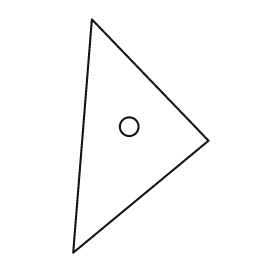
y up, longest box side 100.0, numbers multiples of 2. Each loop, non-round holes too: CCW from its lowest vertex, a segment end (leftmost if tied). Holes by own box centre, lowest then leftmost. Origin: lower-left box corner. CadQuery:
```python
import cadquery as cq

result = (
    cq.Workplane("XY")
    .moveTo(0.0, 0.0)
    .lineTo(58.0, 48.0)
    .lineTo(8.0, 100.0)
    .close()
    .moveTo(24.0, 54.0)
    .circle(4.0)
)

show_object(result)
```